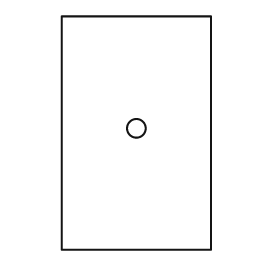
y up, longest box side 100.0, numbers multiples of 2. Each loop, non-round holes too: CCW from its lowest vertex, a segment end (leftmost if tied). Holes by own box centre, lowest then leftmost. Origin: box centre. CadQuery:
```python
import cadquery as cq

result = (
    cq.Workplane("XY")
    .moveTo(-32.0, -50.0)
    .lineTo(32.0, -50.0)
    .lineTo(32.0, 50.0)
    .lineTo(-32.0, 50.0)
    .close()
    .moveTo(0.0, 2.0)
    .circle(4.0)
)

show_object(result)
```